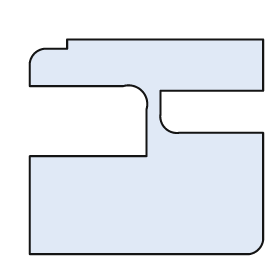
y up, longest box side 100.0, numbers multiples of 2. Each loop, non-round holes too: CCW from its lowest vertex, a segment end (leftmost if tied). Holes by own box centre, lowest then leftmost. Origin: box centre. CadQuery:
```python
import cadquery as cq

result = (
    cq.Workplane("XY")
    .moveTo(-50.0, -46.0)
    .lineTo(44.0, -46.0)
    .threePointArc((48.0, -44.0), (50.0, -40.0))
    .lineTo(50.0, 6.0)
    .lineTo(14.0, 6.0)
    .threePointArc((8.0, 8.0), (6.0, 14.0))
    .lineTo(6.0, 24.0)
    .lineTo(50.0, 24.0)
    .lineTo(50.0, 46.0)
    .lineTo(-34.0, 46.0)
    .lineTo(-34.0, 42.0)
    .lineTo(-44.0, 42.0)
    .threePointArc((-48.0, 40.0), (-50.0, 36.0))
    .lineTo(-50.0, 26.0)
    .lineTo(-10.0, 26.0)
    .threePointArc((-2.0, 24.0), (0.0, 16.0))
    .lineTo(0.0, -4.0)
    .lineTo(-50.0, -4.0)
    .close()
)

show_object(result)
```